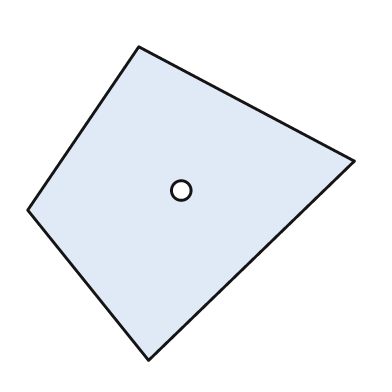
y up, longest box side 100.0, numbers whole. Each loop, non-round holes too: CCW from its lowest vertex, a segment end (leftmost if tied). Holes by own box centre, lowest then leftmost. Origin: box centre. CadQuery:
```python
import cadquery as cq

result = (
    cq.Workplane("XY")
    .moveTo(-13.0, -48.0)
    .lineTo(50.0, 13.0)
    .lineTo(-16.0, 48.0)
    .lineTo(-50.0, -2.0)
    .close()
    .moveTo(-3.0, 4.0)
    .circle(3.0)
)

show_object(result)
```